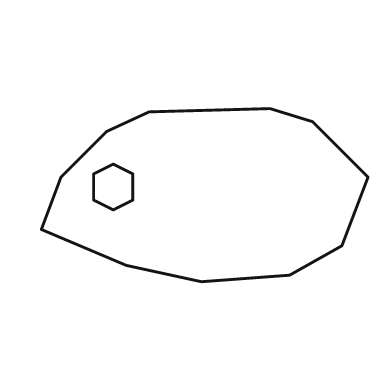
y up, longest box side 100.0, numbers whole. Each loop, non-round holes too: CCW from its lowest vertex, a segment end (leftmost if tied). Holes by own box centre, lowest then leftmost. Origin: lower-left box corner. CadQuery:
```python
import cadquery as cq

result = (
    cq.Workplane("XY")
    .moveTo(49.0, 0.0)
    .lineTo(76.0, 2.0)
    .lineTo(92.0, 11.0)
    .lineTo(100.0, 32.0)
    .lineTo(83.0, 49.0)
    .lineTo(70.0, 53.0)
    .lineTo(33.0, 52.0)
    .lineTo(20.0, 46.0)
    .lineTo(6.0, 32.0)
    .lineTo(0.0, 16.0)
    .lineTo(26.0, 5.0)
    .close()
    .moveTo(22.0, 22.0)
    .lineTo(28.0, 25.0)
    .lineTo(28.0, 33.0)
    .lineTo(22.0, 36.0)
    .lineTo(16.0, 33.0)
    .lineTo(16.0, 25.0)
    .close()
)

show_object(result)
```